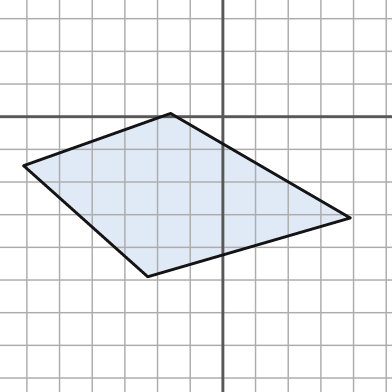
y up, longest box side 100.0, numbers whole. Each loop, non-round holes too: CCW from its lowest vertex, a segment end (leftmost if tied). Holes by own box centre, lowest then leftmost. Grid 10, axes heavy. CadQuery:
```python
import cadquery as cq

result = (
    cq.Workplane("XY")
    .moveTo(-23.0, -49.0)
    .lineTo(39.0, -31.0)
    .lineTo(-16.0, 1.0)
    .lineTo(-61.0, -15.0)
    .close()
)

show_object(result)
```